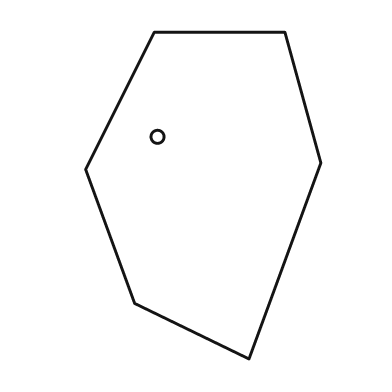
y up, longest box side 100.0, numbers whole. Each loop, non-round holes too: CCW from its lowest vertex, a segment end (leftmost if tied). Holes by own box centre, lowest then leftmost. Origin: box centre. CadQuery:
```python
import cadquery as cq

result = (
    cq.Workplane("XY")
    .moveTo(14.0, -50.0)
    .lineTo(36.0, 10.0)
    .lineTo(25.0, 50.0)
    .lineTo(-15.0, 50.0)
    .lineTo(-36.0, 8.0)
    .lineTo(-21.0, -33.0)
    .close()
    .moveTo(-14.0, 18.0)
    .circle(2.0)
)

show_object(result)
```